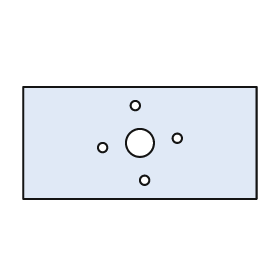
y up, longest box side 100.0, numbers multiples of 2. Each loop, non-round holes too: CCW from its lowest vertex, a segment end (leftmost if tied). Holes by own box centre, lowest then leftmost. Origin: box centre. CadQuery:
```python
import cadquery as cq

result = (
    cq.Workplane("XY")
    .moveTo(-50.0, -24.0)
    .lineTo(50.0, -24.0)
    .lineTo(50.0, 24.0)
    .lineTo(-50.0, 24.0)
    .close()
    .moveTo(2.0, -16.0)
    .circle(2.0)
    .moveTo(-16.0, -2.0)
    .circle(2.0)
    .moveTo(0.0, 0.0)
    .circle(6.0)
    .moveTo(16.0, 2.0)
    .circle(2.0)
    .moveTo(-2.0, 16.0)
    .circle(2.0)
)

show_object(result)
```